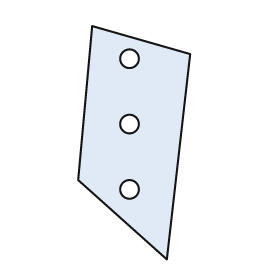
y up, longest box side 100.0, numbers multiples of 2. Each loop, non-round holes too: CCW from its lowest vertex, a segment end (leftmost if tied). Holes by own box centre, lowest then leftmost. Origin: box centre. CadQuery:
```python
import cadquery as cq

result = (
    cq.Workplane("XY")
    .moveTo(14.0, -50.0)
    .lineTo(24.0, 38.0)
    .lineTo(-18.0, 50.0)
    .lineTo(-24.0, -16.0)
    .close()
    .moveTo(-2.0, -20.0)
    .circle(4.0)
    .moveTo(-2.0, 8.0)
    .circle(4.0)
    .moveTo(-2.0, 36.0)
    .circle(4.0)
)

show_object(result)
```